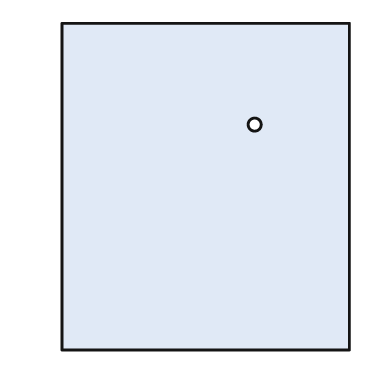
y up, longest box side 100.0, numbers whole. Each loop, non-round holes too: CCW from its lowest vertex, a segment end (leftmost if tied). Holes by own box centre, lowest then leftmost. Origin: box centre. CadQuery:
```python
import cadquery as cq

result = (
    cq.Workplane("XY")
    .moveTo(-44.0, -50.0)
    .lineTo(44.0, -50.0)
    .lineTo(44.0, 50.0)
    .lineTo(-44.0, 50.0)
    .close()
    .moveTo(15.0, 19.0)
    .circle(2.0)
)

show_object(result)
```